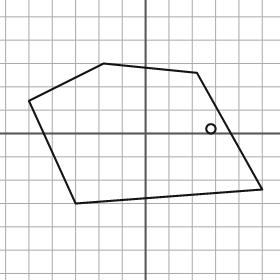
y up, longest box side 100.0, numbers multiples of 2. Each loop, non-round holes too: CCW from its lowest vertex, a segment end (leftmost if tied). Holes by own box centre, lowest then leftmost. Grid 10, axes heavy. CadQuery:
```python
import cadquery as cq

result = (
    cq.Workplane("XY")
    .moveTo(-30.0, -30.0)
    .lineTo(50.0, -24.0)
    .lineTo(22.0, 26.0)
    .lineTo(-18.0, 30.0)
    .lineTo(-50.0, 14.0)
    .close()
    .moveTo(28.0, 2.0)
    .circle(2.0)
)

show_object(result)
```